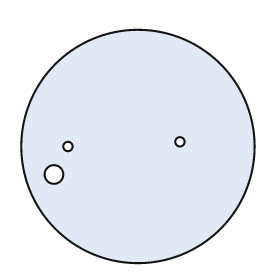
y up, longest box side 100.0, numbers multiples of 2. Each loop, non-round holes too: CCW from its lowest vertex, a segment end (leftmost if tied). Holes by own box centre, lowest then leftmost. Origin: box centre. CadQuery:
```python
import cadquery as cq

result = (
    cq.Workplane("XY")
    .moveTo(0.0, 0.0)
    .circle(50.0)
    .moveTo(-36.0, -12.0)
    .circle(4.0)
    .moveTo(-30.0, 0.0)
    .circle(2.0)
    .moveTo(18.0, 2.0)
    .circle(2.0)
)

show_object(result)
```